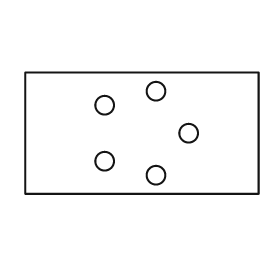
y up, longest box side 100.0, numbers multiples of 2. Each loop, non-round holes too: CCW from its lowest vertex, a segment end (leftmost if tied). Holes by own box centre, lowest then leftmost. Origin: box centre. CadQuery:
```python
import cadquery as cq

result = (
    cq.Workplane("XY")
    .moveTo(-50.0, -26.0)
    .lineTo(50.0, -26.0)
    .lineTo(50.0, 26.0)
    .lineTo(-50.0, 26.0)
    .close()
    .moveTo(6.0, -18.0)
    .circle(4.0)
    .moveTo(-16.0, -12.0)
    .circle(4.0)
    .moveTo(20.0, 0.0)
    .circle(4.0)
    .moveTo(-16.0, 12.0)
    .circle(4.0)
    .moveTo(6.0, 18.0)
    .circle(4.0)
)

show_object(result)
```